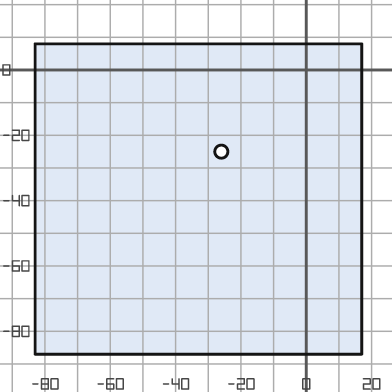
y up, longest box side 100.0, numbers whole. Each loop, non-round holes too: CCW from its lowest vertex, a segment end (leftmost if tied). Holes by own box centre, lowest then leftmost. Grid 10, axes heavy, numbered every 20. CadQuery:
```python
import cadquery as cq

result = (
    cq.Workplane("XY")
    .moveTo(-83.0, -87.0)
    .lineTo(17.0, -87.0)
    .lineTo(17.0, 8.0)
    .lineTo(-83.0, 8.0)
    .close()
    .moveTo(-26.0, -25.0)
    .circle(2.0)
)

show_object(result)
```